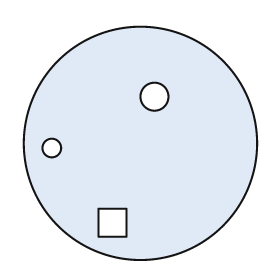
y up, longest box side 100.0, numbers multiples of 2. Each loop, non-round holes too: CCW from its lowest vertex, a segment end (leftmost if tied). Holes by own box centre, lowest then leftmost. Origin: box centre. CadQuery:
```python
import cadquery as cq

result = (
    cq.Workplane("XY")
    .moveTo(0.0, 0.0)
    .circle(50.0)
    .moveTo(-18.0, -40.0)
    .lineTo(-6.0, -40.0)
    .lineTo(-6.0, -28.0)
    .lineTo(-18.0, -28.0)
    .close()
    .moveTo(-38.0, -2.0)
    .circle(4.0)
    .moveTo(6.0, 20.0)
    .circle(6.0)
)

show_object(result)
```